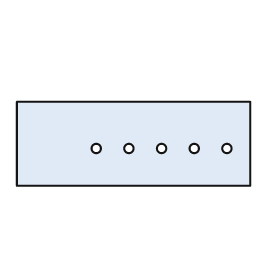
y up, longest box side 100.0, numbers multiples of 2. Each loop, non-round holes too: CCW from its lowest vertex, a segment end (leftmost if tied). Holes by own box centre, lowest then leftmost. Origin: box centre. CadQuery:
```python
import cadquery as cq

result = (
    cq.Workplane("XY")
    .moveTo(-50.0, -18.0)
    .lineTo(50.0, -18.0)
    .lineTo(50.0, 18.0)
    .lineTo(-50.0, 18.0)
    .close()
    .moveTo(-16.0, -2.0)
    .circle(2.0)
    .moveTo(-2.0, -2.0)
    .circle(2.0)
    .moveTo(12.0, -2.0)
    .circle(2.0)
    .moveTo(26.0, -2.0)
    .circle(2.0)
    .moveTo(40.0, -2.0)
    .circle(2.0)
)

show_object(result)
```